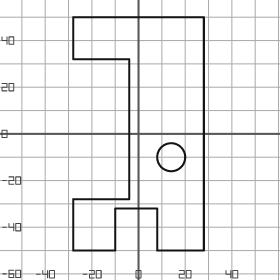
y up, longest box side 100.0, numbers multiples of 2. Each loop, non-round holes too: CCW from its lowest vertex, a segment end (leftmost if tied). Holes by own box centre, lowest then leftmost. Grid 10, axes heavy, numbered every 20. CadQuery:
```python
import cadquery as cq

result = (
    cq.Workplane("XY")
    .moveTo(-28.0, -50.0)
    .lineTo(-10.0, -50.0)
    .lineTo(-10.0, -32.0)
    .lineTo(8.0, -32.0)
    .lineTo(8.0, -50.0)
    .lineTo(28.0, -50.0)
    .lineTo(28.0, 50.0)
    .lineTo(-28.0, 50.0)
    .lineTo(-28.0, 32.0)
    .lineTo(-4.0, 32.0)
    .lineTo(-4.0, -28.0)
    .lineTo(-28.0, -28.0)
    .close()
    .moveTo(14.0, -10.0)
    .circle(6.0)
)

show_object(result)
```